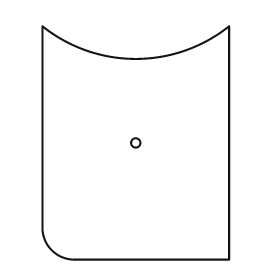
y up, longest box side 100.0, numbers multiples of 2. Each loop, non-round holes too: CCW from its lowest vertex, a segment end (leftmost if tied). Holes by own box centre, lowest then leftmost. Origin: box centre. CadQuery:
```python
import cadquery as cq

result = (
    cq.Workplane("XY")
    .moveTo(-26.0, -50.0)
    .lineTo(40.0, -50.0)
    .lineTo(40.0, 50.0)
    .threePointArc((0.0, 36.0), (-40.0, 50.0))
    .lineTo(-40.0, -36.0)
    .threePointArc((-36.0, -46.0), (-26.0, -50.0))
    .close()
    .moveTo(0.0, 0.0)
    .circle(2.0)
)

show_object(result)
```